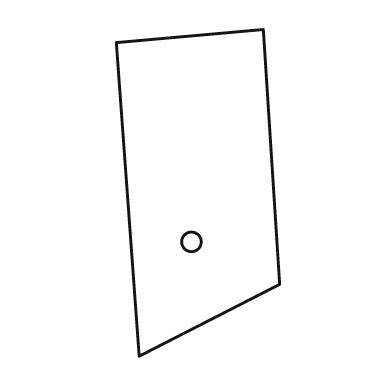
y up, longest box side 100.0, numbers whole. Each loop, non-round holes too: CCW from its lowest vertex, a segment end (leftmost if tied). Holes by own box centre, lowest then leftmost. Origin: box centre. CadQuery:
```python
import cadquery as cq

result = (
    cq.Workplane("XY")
    .moveTo(-18.0, -50.0)
    .lineTo(25.0, -28.0)
    .lineTo(20.0, 50.0)
    .lineTo(-25.0, 46.0)
    .close()
    .moveTo(-2.0, -15.0)
    .circle(3.0)
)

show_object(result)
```